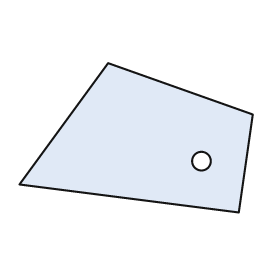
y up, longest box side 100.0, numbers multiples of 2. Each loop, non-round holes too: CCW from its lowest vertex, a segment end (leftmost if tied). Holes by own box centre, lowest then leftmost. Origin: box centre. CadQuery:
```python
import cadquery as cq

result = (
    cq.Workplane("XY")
    .moveTo(44.0, -32.0)
    .lineTo(50.0, 10.0)
    .lineTo(-12.0, 32.0)
    .lineTo(-50.0, -20.0)
    .close()
    .moveTo(28.0, -10.0)
    .circle(4.0)
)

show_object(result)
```